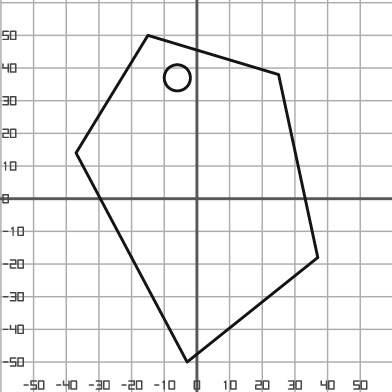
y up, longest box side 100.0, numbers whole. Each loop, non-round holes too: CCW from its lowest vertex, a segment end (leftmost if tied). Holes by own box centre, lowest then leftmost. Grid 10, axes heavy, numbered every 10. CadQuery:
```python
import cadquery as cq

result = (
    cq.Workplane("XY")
    .moveTo(-3.0, -50.0)
    .lineTo(37.0, -18.0)
    .lineTo(25.0, 38.0)
    .lineTo(-15.0, 50.0)
    .lineTo(-37.0, 14.0)
    .close()
    .moveTo(-6.0, 37.0)
    .circle(4.0)
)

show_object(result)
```